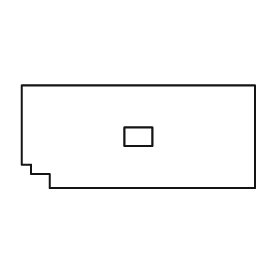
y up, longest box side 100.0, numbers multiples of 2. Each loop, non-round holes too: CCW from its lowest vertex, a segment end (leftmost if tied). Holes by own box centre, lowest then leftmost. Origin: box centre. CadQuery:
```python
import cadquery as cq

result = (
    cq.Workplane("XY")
    .moveTo(-38.0, -22.0)
    .lineTo(50.0, -22.0)
    .lineTo(50.0, 22.0)
    .lineTo(-50.0, 22.0)
    .lineTo(-50.0, -12.0)
    .lineTo(-46.0, -12.0)
    .lineTo(-46.0, -16.0)
    .lineTo(-38.0, -16.0)
    .close()
    .moveTo(-6.0, -4.0)
    .lineTo(6.0, -4.0)
    .lineTo(6.0, 4.0)
    .lineTo(-6.0, 4.0)
    .close()
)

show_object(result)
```